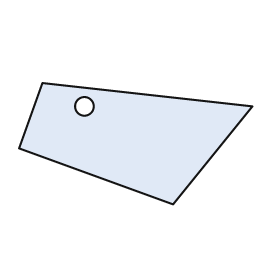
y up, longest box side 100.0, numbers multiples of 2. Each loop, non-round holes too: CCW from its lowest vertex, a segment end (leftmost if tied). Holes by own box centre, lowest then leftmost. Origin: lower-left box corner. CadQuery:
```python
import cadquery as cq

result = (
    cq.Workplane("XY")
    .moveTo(66.0, 0.0)
    .lineTo(100.0, 42.0)
    .lineTo(10.0, 52.0)
    .lineTo(0.0, 24.0)
    .close()
    .moveTo(28.0, 42.0)
    .circle(4.0)
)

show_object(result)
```